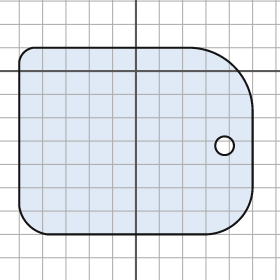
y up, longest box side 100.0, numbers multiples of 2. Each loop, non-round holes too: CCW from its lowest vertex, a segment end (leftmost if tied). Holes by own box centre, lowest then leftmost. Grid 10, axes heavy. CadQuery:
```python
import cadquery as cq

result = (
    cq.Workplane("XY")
    .moveTo(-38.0, -70.0)
    .lineTo(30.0, -70.0)
    .threePointArc((44.0, -64.0), (50.0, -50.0))
    .lineTo(50.0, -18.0)
    .threePointArc((42.0, 2.0), (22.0, 10.0))
    .lineTo(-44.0, 10.0)
    .threePointArc((-48.0, 8.0), (-50.0, 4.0))
    .lineTo(-50.0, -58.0)
    .threePointArc((-46.0, -66.0), (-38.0, -70.0))
    .close()
    .moveTo(38.0, -32.0)
    .circle(4.0)
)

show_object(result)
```